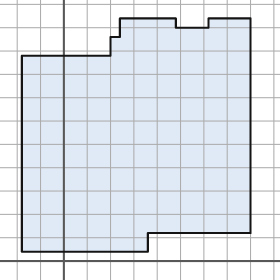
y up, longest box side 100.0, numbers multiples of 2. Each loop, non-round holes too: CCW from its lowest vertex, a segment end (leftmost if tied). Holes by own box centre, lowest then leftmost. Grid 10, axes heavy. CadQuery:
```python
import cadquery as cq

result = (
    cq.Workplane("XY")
    .moveTo(-18.0, 4.0)
    .lineTo(36.0, 4.0)
    .lineTo(36.0, 12.0)
    .lineTo(80.0, 12.0)
    .lineTo(80.0, 104.0)
    .lineTo(62.0, 104.0)
    .lineTo(62.0, 100.0)
    .lineTo(48.0, 100.0)
    .lineTo(48.0, 104.0)
    .lineTo(24.0, 104.0)
    .lineTo(24.0, 96.0)
    .lineTo(20.0, 96.0)
    .lineTo(20.0, 88.0)
    .lineTo(-18.0, 88.0)
    .close()
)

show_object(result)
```